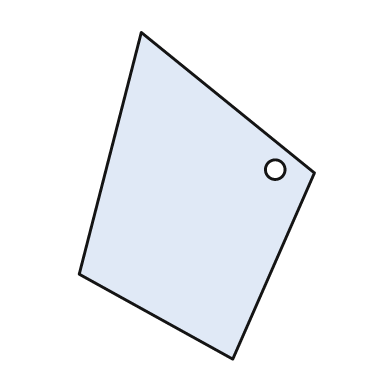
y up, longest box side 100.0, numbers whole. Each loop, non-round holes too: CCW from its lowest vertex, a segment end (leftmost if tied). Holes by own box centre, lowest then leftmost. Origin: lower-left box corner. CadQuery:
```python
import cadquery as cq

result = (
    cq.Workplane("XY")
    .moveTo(47.0, 0.0)
    .lineTo(72.0, 57.0)
    .lineTo(19.0, 100.0)
    .lineTo(0.0, 26.0)
    .close()
    .moveTo(60.0, 58.0)
    .circle(3.0)
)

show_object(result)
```